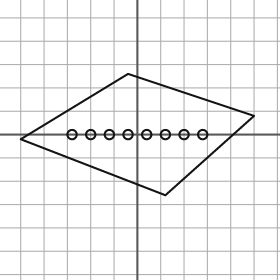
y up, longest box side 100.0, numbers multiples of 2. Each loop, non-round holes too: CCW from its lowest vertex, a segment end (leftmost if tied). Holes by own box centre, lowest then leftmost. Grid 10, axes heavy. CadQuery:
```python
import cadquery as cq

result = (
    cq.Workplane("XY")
    .moveTo(12.0, -26.0)
    .lineTo(50.0, 8.0)
    .lineTo(-4.0, 26.0)
    .lineTo(-50.0, -2.0)
    .close()
    .moveTo(-28.0, 0.0)
    .circle(2.0)
    .moveTo(-20.0, 0.0)
    .circle(2.0)
    .moveTo(-12.0, 0.0)
    .circle(2.0)
    .moveTo(-4.0, 0.0)
    .circle(2.0)
    .moveTo(4.0, 0.0)
    .circle(2.0)
    .moveTo(12.0, 0.0)
    .circle(2.0)
    .moveTo(20.0, 0.0)
    .circle(2.0)
    .moveTo(28.0, 0.0)
    .circle(2.0)
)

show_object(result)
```